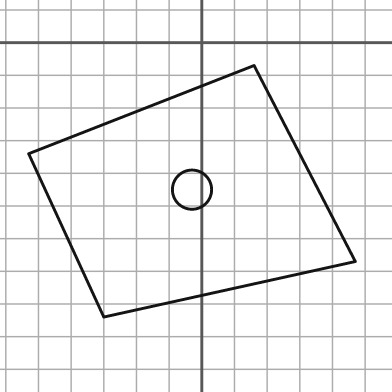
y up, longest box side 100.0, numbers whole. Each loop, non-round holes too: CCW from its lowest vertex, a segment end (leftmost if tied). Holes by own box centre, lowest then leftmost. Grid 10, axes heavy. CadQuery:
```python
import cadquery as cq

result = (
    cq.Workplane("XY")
    .moveTo(-30.0, -84.0)
    .lineTo(47.0, -67.0)
    .lineTo(16.0, -7.0)
    .lineTo(-53.0, -34.0)
    .close()
    .moveTo(-3.0, -45.0)
    .circle(6.0)
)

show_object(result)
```